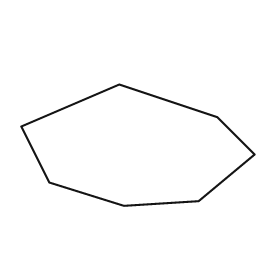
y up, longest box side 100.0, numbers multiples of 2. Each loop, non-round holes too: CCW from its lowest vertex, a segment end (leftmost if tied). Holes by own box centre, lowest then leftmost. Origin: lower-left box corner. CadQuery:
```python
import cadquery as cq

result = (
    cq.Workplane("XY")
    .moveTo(44.0, 0.0)
    .lineTo(76.0, 2.0)
    .lineTo(100.0, 22.0)
    .lineTo(84.0, 38.0)
    .lineTo(42.0, 52.0)
    .lineTo(0.0, 34.0)
    .lineTo(12.0, 10.0)
    .close()
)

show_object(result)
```